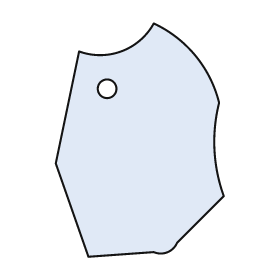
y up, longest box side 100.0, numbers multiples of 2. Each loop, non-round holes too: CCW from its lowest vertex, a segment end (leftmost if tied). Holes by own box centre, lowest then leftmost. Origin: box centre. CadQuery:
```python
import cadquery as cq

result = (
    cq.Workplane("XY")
    .moveTo(-22.0, -50.0)
    .lineTo(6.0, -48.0)
    .threePointArc((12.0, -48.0), (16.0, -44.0))
    .lineTo(36.0, -24.0)
    .threePointArc((32.0, -4.0), (34.0, 16.0))
    .threePointArc((24.0, 36.0), (6.0, 50.0))
    .threePointArc((-8.0, 38.0), (-26.0, 38.0))
    .lineTo(-36.0, -10.0)
    .close()
    .moveTo(-14.0, 22.0)
    .circle(4.0)
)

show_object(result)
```